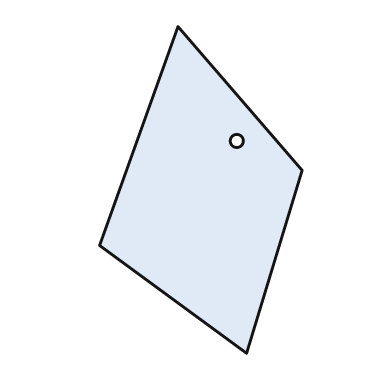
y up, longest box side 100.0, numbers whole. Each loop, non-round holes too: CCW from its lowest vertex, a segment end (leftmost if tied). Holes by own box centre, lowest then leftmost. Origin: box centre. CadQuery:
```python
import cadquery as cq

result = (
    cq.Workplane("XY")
    .moveTo(14.0, -50.0)
    .lineTo(31.0, 6.0)
    .lineTo(-7.0, 50.0)
    .lineTo(-31.0, -17.0)
    .close()
    .moveTo(11.0, 15.0)
    .circle(2.0)
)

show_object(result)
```